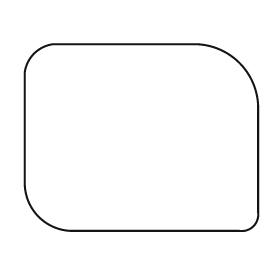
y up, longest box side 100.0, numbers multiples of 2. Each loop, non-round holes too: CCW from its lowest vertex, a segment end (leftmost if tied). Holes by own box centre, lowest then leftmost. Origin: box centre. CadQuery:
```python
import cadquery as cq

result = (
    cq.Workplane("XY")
    .moveTo(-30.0, -40.0)
    .lineTo(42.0, -40.0)
    .threePointArc((48.0, -38.0), (50.0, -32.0))
    .lineTo(50.0, 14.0)
    .threePointArc((42.0, 32.0), (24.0, 40.0))
    .lineTo(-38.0, 40.0)
    .threePointArc((-46.0, 36.0), (-50.0, 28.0))
    .lineTo(-50.0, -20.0)
    .threePointArc((-44.0, -34.0), (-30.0, -40.0))
    .close()
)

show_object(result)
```